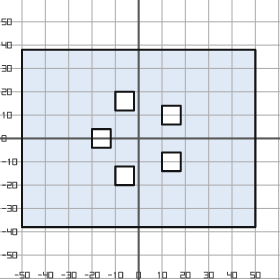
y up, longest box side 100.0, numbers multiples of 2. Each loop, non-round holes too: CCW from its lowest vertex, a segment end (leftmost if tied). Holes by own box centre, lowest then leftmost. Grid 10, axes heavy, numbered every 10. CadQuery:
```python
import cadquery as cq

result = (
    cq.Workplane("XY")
    .moveTo(-50.0, -38.0)
    .lineTo(50.0, -38.0)
    .lineTo(50.0, 38.0)
    .lineTo(-50.0, 38.0)
    .close()
    .moveTo(-10.0, -20.0)
    .lineTo(-2.0, -20.0)
    .lineTo(-2.0, -12.0)
    .lineTo(-10.0, -12.0)
    .close()
    .moveTo(10.0, -14.0)
    .lineTo(18.0, -14.0)
    .lineTo(18.0, -6.0)
    .lineTo(10.0, -6.0)
    .close()
    .moveTo(-20.0, -4.0)
    .lineTo(-12.0, -4.0)
    .lineTo(-12.0, 4.0)
    .lineTo(-20.0, 4.0)
    .close()
    .moveTo(10.0, 6.0)
    .lineTo(18.0, 6.0)
    .lineTo(18.0, 14.0)
    .lineTo(10.0, 14.0)
    .close()
    .moveTo(-10.0, 12.0)
    .lineTo(-2.0, 12.0)
    .lineTo(-2.0, 20.0)
    .lineTo(-10.0, 20.0)
    .close()
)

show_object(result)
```